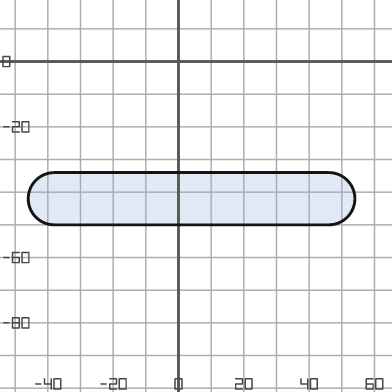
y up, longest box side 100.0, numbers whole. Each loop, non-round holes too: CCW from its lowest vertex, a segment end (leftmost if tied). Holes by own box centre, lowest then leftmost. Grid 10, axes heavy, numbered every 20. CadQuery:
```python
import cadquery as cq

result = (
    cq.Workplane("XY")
    .moveTo(-38.0, -50.0)
    .lineTo(46.0, -50.0)
    .threePointArc((54.0, -42.0), (46.0, -34.0))
    .lineTo(-38.0, -34.0)
    .threePointArc((-46.0, -42.0), (-38.0, -50.0))
    .close()
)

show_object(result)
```